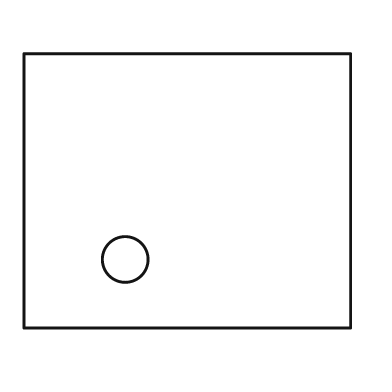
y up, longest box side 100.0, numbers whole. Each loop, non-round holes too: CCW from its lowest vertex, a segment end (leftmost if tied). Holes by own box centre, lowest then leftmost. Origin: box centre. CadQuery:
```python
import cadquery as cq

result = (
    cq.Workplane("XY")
    .moveTo(-50.0, -42.0)
    .lineTo(50.0, -42.0)
    .lineTo(50.0, 42.0)
    .lineTo(-50.0, 42.0)
    .close()
    .moveTo(-19.0, -21.0)
    .circle(7.0)
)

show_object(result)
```